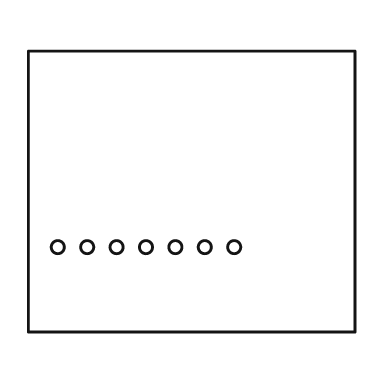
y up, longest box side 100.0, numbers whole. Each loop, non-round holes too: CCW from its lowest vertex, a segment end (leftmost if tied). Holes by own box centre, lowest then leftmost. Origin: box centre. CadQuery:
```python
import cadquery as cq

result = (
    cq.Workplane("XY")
    .moveTo(-50.0, -43.0)
    .lineTo(50.0, -43.0)
    .lineTo(50.0, 43.0)
    .lineTo(-50.0, 43.0)
    .close()
    .moveTo(-41.0, -17.0)
    .circle(2.0)
    .moveTo(-32.0, -17.0)
    .circle(2.0)
    .moveTo(-23.0, -17.0)
    .circle(2.0)
    .moveTo(-14.0, -17.0)
    .circle(2.0)
    .moveTo(-5.0, -17.0)
    .circle(2.0)
    .moveTo(4.0, -17.0)
    .circle(2.0)
    .moveTo(13.0, -17.0)
    .circle(2.0)
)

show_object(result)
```